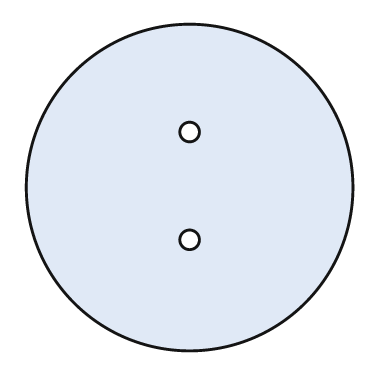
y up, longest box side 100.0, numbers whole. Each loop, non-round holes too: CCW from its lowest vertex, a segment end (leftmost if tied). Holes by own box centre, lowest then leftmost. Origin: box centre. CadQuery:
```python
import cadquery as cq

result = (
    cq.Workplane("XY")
    .moveTo(0.0, 0.0)
    .circle(50.0)
    .moveTo(0.0, -16.0)
    .circle(3.0)
    .moveTo(0.0, 17.0)
    .circle(3.0)
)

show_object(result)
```